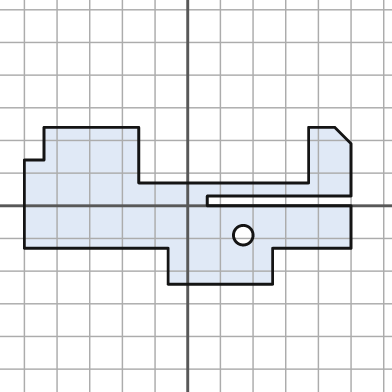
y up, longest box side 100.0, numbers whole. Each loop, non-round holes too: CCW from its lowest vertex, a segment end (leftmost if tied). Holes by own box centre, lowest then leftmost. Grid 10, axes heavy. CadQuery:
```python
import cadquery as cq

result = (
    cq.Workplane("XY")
    .moveTo(-6.0, -24.0)
    .lineTo(26.0, -24.0)
    .lineTo(26.0, -13.0)
    .lineTo(50.0, -13.0)
    .lineTo(50.0, 0.0)
    .lineTo(6.0, 0.0)
    .lineTo(6.0, 3.0)
    .lineTo(50.0, 3.0)
    .lineTo(50.0, 19.0)
    .lineTo(45.0, 24.0)
    .lineTo(37.0, 24.0)
    .lineTo(37.0, 7.0)
    .lineTo(-15.0, 7.0)
    .lineTo(-15.0, 24.0)
    .lineTo(-44.0, 24.0)
    .lineTo(-44.0, 14.0)
    .lineTo(-50.0, 14.0)
    .lineTo(-50.0, -13.0)
    .lineTo(-6.0, -13.0)
    .close()
    .moveTo(17.0, -9.0)
    .circle(3.0)
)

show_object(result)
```